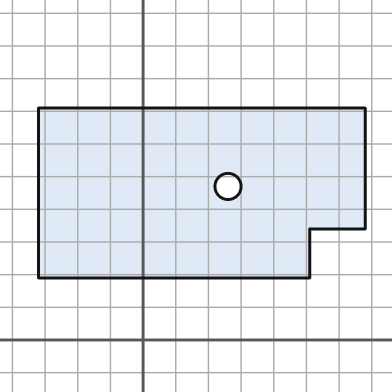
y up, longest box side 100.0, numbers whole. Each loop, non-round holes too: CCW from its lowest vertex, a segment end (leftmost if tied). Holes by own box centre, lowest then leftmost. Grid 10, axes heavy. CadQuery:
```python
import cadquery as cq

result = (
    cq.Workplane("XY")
    .moveTo(-32.0, 19.0)
    .lineTo(51.0, 19.0)
    .lineTo(51.0, 34.0)
    .lineTo(68.0, 34.0)
    .lineTo(68.0, 71.0)
    .lineTo(-32.0, 71.0)
    .close()
    .moveTo(26.0, 47.0)
    .circle(4.0)
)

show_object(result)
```